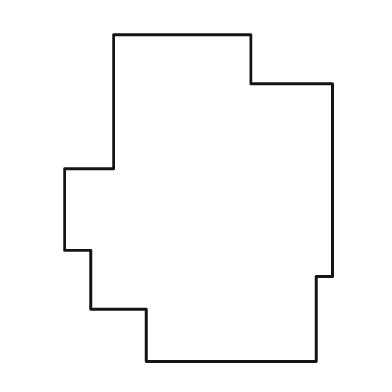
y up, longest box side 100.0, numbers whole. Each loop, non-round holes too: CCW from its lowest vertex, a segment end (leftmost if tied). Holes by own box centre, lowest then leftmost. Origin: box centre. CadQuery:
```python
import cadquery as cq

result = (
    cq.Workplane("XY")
    .moveTo(-16.0, -50.0)
    .lineTo(36.0, -50.0)
    .lineTo(36.0, -24.0)
    .lineTo(41.0, -24.0)
    .lineTo(41.0, 35.0)
    .lineTo(16.0, 35.0)
    .lineTo(16.0, 50.0)
    .lineTo(-26.0, 50.0)
    .lineTo(-26.0, 9.0)
    .lineTo(-41.0, 9.0)
    .lineTo(-41.0, -16.0)
    .lineTo(-33.0, -16.0)
    .lineTo(-33.0, -34.0)
    .lineTo(-16.0, -34.0)
    .close()
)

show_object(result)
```